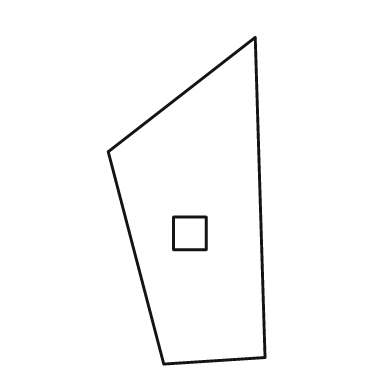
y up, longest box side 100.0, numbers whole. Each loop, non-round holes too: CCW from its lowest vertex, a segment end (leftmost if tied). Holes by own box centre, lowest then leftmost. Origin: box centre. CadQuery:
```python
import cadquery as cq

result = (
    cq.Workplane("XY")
    .moveTo(-7.0, -50.0)
    .lineTo(24.0, -48.0)
    .lineTo(21.0, 50.0)
    .lineTo(-24.0, 15.0)
    .close()
    .moveTo(-4.0, -15.0)
    .lineTo(6.0, -15.0)
    .lineTo(6.0, -5.0)
    .lineTo(-4.0, -5.0)
    .close()
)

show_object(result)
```